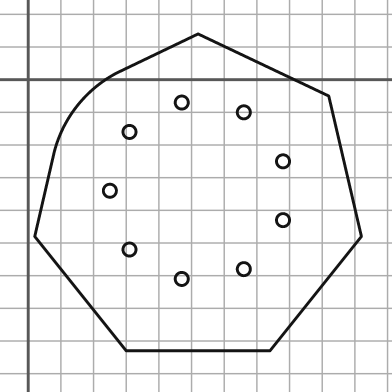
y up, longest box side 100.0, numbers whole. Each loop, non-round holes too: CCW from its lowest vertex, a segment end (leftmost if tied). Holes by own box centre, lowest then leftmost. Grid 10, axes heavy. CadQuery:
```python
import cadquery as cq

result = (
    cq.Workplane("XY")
    .moveTo(30.0, -83.0)
    .lineTo(74.0, -83.0)
    .lineTo(102.0, -48.0)
    .lineTo(92.0, -5.0)
    .lineTo(52.0, 14.0)
    .lineTo(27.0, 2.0)
    .threePointArc((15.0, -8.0), (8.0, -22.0))
    .lineTo(2.0, -48.0)
    .close()
    .moveTo(47.0, -61.0)
    .circle(2.0)
    .moveTo(66.0, -58.0)
    .circle(2.0)
    .moveTo(31.0, -52.0)
    .circle(2.0)
    .moveTo(78.0, -43.0)
    .circle(2.0)
    .moveTo(25.0, -34.0)
    .circle(2.0)
    .moveTo(78.0, -25.0)
    .circle(2.0)
    .moveTo(31.0, -16.0)
    .circle(2.0)
    .moveTo(66.0, -10.0)
    .circle(2.0)
    .moveTo(47.0, -7.0)
    .circle(2.0)
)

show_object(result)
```